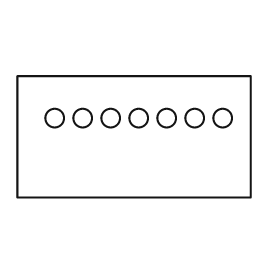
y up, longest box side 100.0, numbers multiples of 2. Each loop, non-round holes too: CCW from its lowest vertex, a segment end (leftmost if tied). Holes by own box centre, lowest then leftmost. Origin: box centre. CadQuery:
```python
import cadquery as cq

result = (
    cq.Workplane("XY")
    .moveTo(-50.0, -26.0)
    .lineTo(50.0, -26.0)
    .lineTo(50.0, 26.0)
    .lineTo(-50.0, 26.0)
    .close()
    .moveTo(-34.0, 8.0)
    .circle(4.0)
    .moveTo(-22.0, 8.0)
    .circle(4.0)
    .moveTo(-10.0, 8.0)
    .circle(4.0)
    .moveTo(2.0, 8.0)
    .circle(4.0)
    .moveTo(14.0, 8.0)
    .circle(4.0)
    .moveTo(26.0, 8.0)
    .circle(4.0)
    .moveTo(38.0, 8.0)
    .circle(4.0)
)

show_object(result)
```